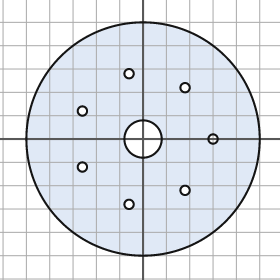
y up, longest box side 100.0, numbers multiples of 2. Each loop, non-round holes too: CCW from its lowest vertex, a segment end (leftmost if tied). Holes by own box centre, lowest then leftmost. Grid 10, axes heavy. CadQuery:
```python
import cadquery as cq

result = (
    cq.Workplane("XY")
    .moveTo(0.0, 0.0)
    .circle(50.0)
    .moveTo(-6.0, -28.0)
    .circle(2.0)
    .moveTo(18.0, -22.0)
    .circle(2.0)
    .moveTo(-26.0, -12.0)
    .circle(2.0)
    .moveTo(0.0, 0.0)
    .circle(8.0)
    .moveTo(30.0, 0.0)
    .circle(2.0)
    .moveTo(-26.0, 12.0)
    .circle(2.0)
    .moveTo(18.0, 22.0)
    .circle(2.0)
    .moveTo(-6.0, 28.0)
    .circle(2.0)
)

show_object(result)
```